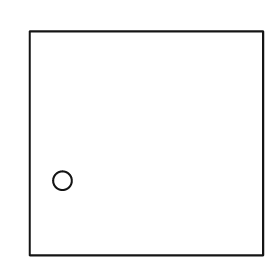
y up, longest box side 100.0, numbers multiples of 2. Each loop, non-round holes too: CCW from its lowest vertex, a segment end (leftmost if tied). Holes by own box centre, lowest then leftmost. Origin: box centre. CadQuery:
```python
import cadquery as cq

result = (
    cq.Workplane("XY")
    .moveTo(-50.0, -48.0)
    .lineTo(50.0, -48.0)
    .lineTo(50.0, 48.0)
    .lineTo(-50.0, 48.0)
    .close()
    .moveTo(-36.0, -16.0)
    .circle(4.0)
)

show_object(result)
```